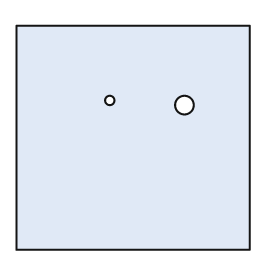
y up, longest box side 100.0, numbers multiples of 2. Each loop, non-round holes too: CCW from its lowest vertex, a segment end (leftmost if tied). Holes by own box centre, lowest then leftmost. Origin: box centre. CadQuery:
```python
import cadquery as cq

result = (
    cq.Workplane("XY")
    .moveTo(-50.0, -48.0)
    .lineTo(50.0, -48.0)
    .lineTo(50.0, 48.0)
    .lineTo(-50.0, 48.0)
    .close()
    .moveTo(22.0, 14.0)
    .circle(4.0)
    .moveTo(-10.0, 16.0)
    .circle(2.0)
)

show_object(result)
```